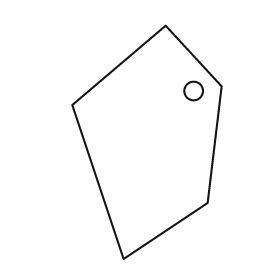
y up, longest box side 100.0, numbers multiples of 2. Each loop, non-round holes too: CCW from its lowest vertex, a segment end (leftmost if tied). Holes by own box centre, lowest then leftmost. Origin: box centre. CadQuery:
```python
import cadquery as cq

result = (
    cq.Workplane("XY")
    .moveTo(-10.0, -50.0)
    .lineTo(26.0, -26.0)
    .lineTo(32.0, 24.0)
    .lineTo(8.0, 50.0)
    .lineTo(-32.0, 16.0)
    .close()
    .moveTo(20.0, 22.0)
    .circle(4.0)
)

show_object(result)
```